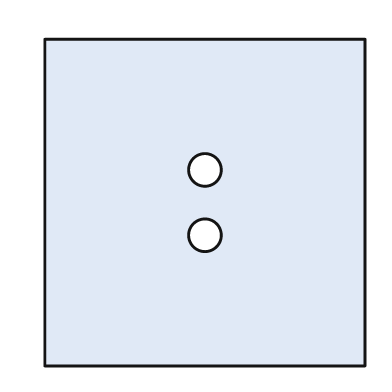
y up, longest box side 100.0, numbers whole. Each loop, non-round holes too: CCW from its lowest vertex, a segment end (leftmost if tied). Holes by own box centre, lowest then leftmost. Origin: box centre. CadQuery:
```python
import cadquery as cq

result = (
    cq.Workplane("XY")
    .moveTo(-49.0, -50.0)
    .lineTo(49.0, -50.0)
    .lineTo(49.0, 50.0)
    .lineTo(-49.0, 50.0)
    .close()
    .moveTo(0.0, -10.0)
    .circle(5.0)
    .moveTo(0.0, 10.0)
    .circle(5.0)
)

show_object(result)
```